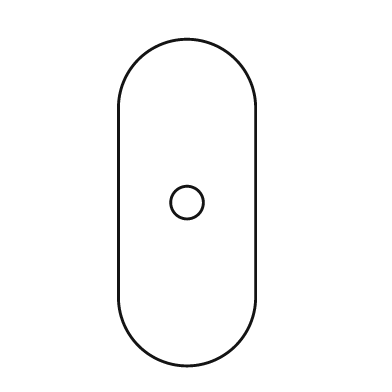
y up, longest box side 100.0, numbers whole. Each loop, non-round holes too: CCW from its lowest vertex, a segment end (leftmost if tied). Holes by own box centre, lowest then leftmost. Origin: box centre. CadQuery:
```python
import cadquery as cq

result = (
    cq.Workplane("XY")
    .moveTo(-21.0, -29.0)
    .threePointArc((0.0, -50.0), (21.0, -29.0))
    .lineTo(21.0, 29.0)
    .threePointArc((0.0, 50.0), (-21.0, 29.0))
    .close()
    .moveTo(0.0, 0.0)
    .circle(5.0)
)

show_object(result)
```